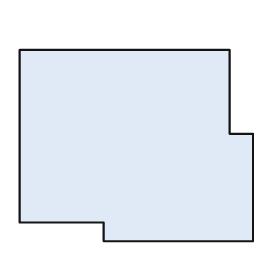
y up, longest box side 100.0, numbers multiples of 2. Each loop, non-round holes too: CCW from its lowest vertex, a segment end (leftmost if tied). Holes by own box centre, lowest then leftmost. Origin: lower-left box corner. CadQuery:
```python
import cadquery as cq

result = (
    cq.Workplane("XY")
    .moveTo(36.0, 0.0)
    .lineTo(100.0, 0.0)
    .lineTo(100.0, 46.0)
    .lineTo(90.0, 46.0)
    .lineTo(90.0, 82.0)
    .lineTo(0.0, 82.0)
    .lineTo(0.0, 8.0)
    .lineTo(36.0, 8.0)
    .close()
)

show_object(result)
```